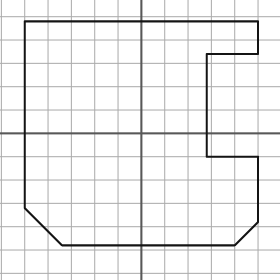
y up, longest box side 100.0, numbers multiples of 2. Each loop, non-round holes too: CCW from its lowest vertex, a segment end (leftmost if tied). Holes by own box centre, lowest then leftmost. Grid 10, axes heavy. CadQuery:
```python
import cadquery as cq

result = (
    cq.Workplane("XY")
    .moveTo(-34.0, -48.0)
    .lineTo(40.0, -48.0)
    .lineTo(50.0, -38.0)
    .lineTo(50.0, -10.0)
    .lineTo(28.0, -10.0)
    .lineTo(28.0, 34.0)
    .lineTo(50.0, 34.0)
    .lineTo(50.0, 48.0)
    .lineTo(-50.0, 48.0)
    .lineTo(-50.0, -32.0)
    .close()
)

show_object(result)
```